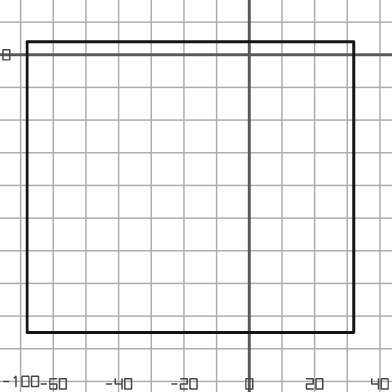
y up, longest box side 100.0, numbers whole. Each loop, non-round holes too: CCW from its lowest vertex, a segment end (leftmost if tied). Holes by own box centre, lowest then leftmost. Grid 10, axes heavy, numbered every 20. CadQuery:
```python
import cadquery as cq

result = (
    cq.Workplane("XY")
    .moveTo(-68.0, -85.0)
    .lineTo(32.0, -85.0)
    .lineTo(32.0, 4.0)
    .lineTo(-68.0, 4.0)
    .close()
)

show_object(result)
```